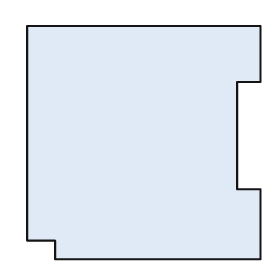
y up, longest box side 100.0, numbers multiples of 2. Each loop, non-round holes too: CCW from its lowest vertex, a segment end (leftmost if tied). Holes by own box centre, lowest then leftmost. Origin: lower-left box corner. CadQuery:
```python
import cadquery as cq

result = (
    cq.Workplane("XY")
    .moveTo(12.0, 0.0)
    .lineTo(100.0, 0.0)
    .lineTo(100.0, 30.0)
    .lineTo(90.0, 30.0)
    .lineTo(90.0, 76.0)
    .lineTo(100.0, 76.0)
    .lineTo(100.0, 100.0)
    .lineTo(0.0, 100.0)
    .lineTo(0.0, 8.0)
    .lineTo(12.0, 8.0)
    .close()
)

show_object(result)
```